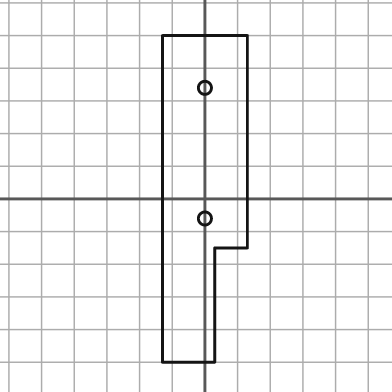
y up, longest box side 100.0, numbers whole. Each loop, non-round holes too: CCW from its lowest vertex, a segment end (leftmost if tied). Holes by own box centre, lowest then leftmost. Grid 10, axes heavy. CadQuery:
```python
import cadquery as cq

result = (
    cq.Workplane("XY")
    .moveTo(-13.0, -50.0)
    .lineTo(3.0, -50.0)
    .lineTo(3.0, -15.0)
    .lineTo(13.0, -15.0)
    .lineTo(13.0, 50.0)
    .lineTo(-13.0, 50.0)
    .close()
    .moveTo(0.0, -6.0)
    .circle(2.0)
    .moveTo(0.0, 34.0)
    .circle(2.0)
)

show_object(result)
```